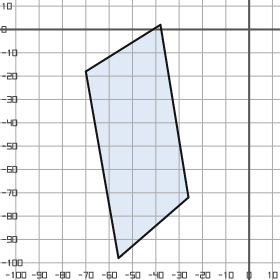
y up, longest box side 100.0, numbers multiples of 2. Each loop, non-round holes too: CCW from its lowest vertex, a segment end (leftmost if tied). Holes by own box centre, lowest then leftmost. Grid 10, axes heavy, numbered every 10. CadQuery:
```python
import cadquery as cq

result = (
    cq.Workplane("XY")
    .moveTo(-56.0, -98.0)
    .lineTo(-26.0, -72.0)
    .lineTo(-38.0, 2.0)
    .lineTo(-70.0, -18.0)
    .close()
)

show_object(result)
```